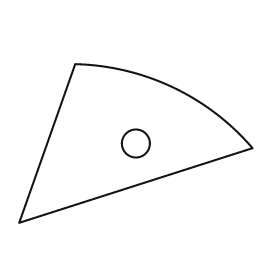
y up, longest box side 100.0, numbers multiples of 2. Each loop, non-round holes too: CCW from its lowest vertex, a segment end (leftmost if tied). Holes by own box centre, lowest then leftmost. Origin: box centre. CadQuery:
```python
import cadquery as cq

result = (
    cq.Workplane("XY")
    .moveTo(-50.0, -34.0)
    .lineTo(50.0, -2.0)
    .threePointArc((16.0, 24.0), (-26.0, 34.0))
    .close()
    .moveTo(0.0, 0.0)
    .circle(6.0)
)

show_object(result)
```